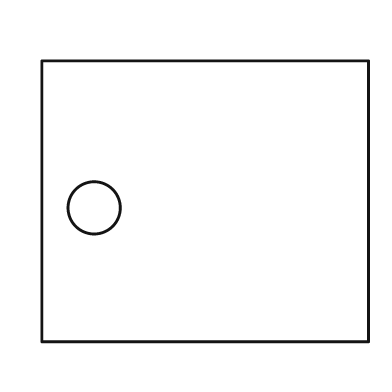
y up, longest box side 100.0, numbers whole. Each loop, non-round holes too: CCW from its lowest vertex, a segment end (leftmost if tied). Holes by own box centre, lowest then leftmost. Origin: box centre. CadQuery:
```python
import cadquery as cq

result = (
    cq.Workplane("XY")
    .moveTo(-50.0, -43.0)
    .lineTo(50.0, -43.0)
    .lineTo(50.0, 43.0)
    .lineTo(-50.0, 43.0)
    .close()
    .moveTo(-34.0, -2.0)
    .circle(8.0)
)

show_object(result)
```